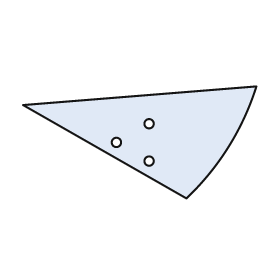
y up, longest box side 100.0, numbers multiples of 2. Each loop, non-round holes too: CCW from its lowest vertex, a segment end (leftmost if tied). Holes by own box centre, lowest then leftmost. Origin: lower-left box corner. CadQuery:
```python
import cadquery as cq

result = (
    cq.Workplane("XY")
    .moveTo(70.0, 0.0)
    .threePointArc((88.0, 22.0), (100.0, 48.0))
    .lineTo(0.0, 40.0)
    .close()
    .moveTo(54.0, 16.0)
    .circle(2.0)
    .moveTo(40.0, 24.0)
    .circle(2.0)
    .moveTo(54.0, 32.0)
    .circle(2.0)
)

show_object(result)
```